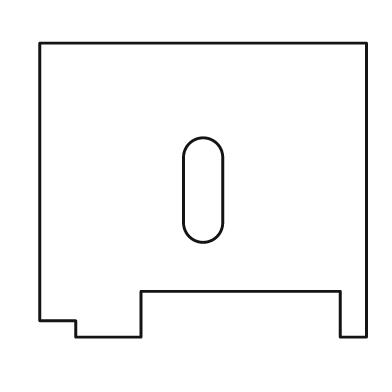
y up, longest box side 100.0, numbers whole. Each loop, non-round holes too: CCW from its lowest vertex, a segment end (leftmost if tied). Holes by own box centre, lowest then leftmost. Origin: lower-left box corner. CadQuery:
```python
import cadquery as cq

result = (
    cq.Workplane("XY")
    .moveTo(11.0, 0.0)
    .lineTo(31.0, 0.0)
    .lineTo(31.0, 14.0)
    .lineTo(92.0, 14.0)
    .lineTo(92.0, 0.0)
    .lineTo(100.0, 0.0)
    .lineTo(100.0, 90.0)
    .lineTo(0.0, 90.0)
    .lineTo(0.0, 5.0)
    .lineTo(11.0, 5.0)
    .close()
    .moveTo(44.0, 35.0)
    .threePointArc((50.0, 29.0), (56.0, 35.0))
    .lineTo(56.0, 55.0)
    .threePointArc((50.0, 61.0), (44.0, 55.0))
    .close()
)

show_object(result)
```